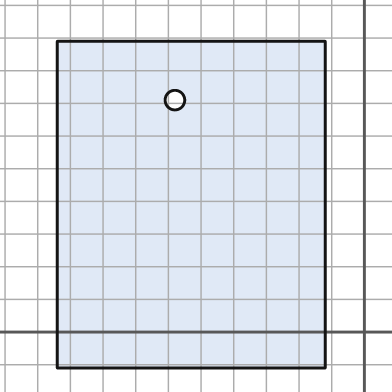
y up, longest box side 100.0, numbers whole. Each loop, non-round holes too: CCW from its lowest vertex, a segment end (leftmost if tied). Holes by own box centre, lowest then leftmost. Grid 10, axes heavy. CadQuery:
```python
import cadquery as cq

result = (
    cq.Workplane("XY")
    .moveTo(-94.0, -11.0)
    .lineTo(-12.0, -11.0)
    .lineTo(-12.0, 89.0)
    .lineTo(-94.0, 89.0)
    .close()
    .moveTo(-58.0, 71.0)
    .circle(3.0)
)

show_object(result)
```